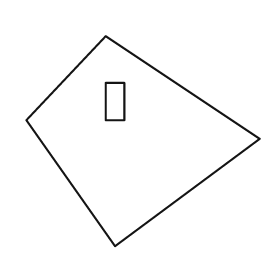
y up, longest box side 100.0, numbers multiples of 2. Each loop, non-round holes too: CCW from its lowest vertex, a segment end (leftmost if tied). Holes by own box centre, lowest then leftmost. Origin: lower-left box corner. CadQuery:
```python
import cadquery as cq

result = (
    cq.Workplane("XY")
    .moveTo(38.0, 0.0)
    .lineTo(100.0, 46.0)
    .lineTo(34.0, 90.0)
    .lineTo(0.0, 54.0)
    .close()
    .moveTo(34.0, 54.0)
    .lineTo(42.0, 54.0)
    .lineTo(42.0, 70.0)
    .lineTo(34.0, 70.0)
    .close()
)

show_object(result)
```